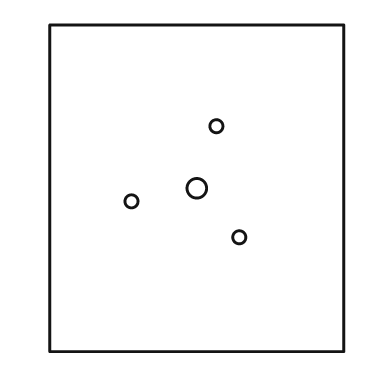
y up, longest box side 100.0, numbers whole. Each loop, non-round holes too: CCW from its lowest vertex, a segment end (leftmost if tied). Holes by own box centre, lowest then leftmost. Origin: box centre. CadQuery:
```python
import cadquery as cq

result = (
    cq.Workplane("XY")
    .moveTo(-45.0, -50.0)
    .lineTo(45.0, -50.0)
    .lineTo(45.0, 50.0)
    .lineTo(-45.0, 50.0)
    .close()
    .moveTo(13.0, -15.0)
    .circle(2.0)
    .moveTo(-20.0, -4.0)
    .circle(2.0)
    .moveTo(0.0, 0.0)
    .circle(3.0)
    .moveTo(6.0, 19.0)
    .circle(2.0)
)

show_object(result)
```